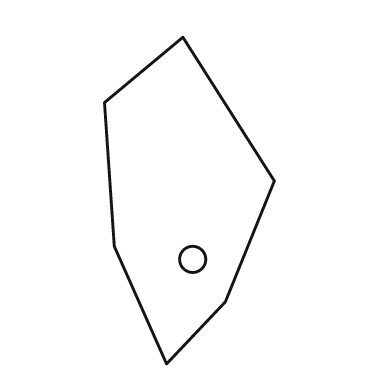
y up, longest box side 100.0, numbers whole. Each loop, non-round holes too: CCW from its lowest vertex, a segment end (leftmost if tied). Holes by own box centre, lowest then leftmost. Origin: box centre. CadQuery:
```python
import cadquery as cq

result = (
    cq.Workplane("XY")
    .moveTo(-7.0, -50.0)
    .lineTo(11.0, -31.0)
    .lineTo(26.0, 6.0)
    .lineTo(-2.0, 50.0)
    .lineTo(-26.0, 30.0)
    .lineTo(-23.0, -14.0)
    .close()
    .moveTo(1.0, -18.0)
    .circle(4.0)
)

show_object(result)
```